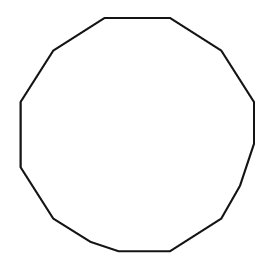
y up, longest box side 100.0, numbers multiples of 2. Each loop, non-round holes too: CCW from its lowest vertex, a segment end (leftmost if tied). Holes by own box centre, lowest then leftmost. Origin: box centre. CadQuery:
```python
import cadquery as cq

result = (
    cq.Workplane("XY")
    .moveTo(-8.0, -50.0)
    .lineTo(14.0, -50.0)
    .lineTo(36.0, -36.0)
    .lineTo(44.0, -22.0)
    .lineTo(50.0, -4.0)
    .lineTo(50.0, 14.0)
    .lineTo(36.0, 36.0)
    .lineTo(14.0, 50.0)
    .lineTo(-14.0, 50.0)
    .lineTo(-36.0, 36.0)
    .lineTo(-50.0, 14.0)
    .lineTo(-50.0, -14.0)
    .lineTo(-36.0, -36.0)
    .lineTo(-20.0, -46.0)
    .close()
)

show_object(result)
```